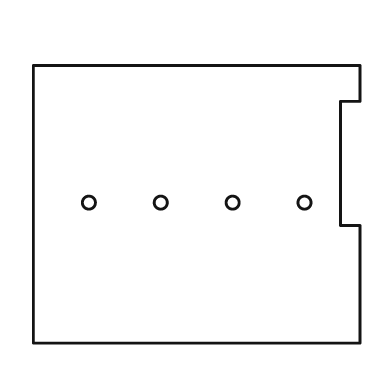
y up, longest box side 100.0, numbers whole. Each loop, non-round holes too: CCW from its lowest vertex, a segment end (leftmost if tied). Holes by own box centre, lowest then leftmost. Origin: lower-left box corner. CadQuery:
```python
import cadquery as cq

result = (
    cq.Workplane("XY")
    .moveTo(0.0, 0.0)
    .lineTo(100.0, 0.0)
    .lineTo(100.0, 36.0)
    .lineTo(94.0, 36.0)
    .lineTo(94.0, 74.0)
    .lineTo(100.0, 74.0)
    .lineTo(100.0, 85.0)
    .lineTo(0.0, 85.0)
    .close()
    .moveTo(17.0, 43.0)
    .circle(2.0)
    .moveTo(39.0, 43.0)
    .circle(2.0)
    .moveTo(61.0, 43.0)
    .circle(2.0)
    .moveTo(83.0, 43.0)
    .circle(2.0)
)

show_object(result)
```